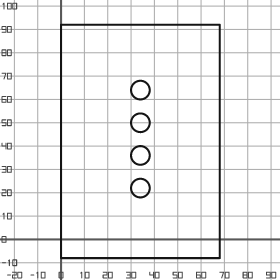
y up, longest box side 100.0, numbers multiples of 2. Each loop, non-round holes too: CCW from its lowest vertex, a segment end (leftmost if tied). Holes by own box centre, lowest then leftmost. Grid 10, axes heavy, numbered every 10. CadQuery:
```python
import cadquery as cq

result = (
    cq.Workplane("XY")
    .moveTo(0.0, -8.0)
    .lineTo(68.0, -8.0)
    .lineTo(68.0, 92.0)
    .lineTo(0.0, 92.0)
    .close()
    .moveTo(34.0, 22.0)
    .circle(4.0)
    .moveTo(34.0, 36.0)
    .circle(4.0)
    .moveTo(34.0, 50.0)
    .circle(4.0)
    .moveTo(34.0, 64.0)
    .circle(4.0)
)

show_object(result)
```